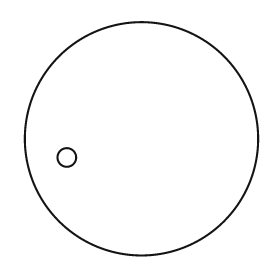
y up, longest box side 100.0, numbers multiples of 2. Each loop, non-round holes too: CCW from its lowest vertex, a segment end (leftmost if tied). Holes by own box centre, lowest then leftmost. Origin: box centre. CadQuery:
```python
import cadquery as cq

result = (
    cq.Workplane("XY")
    .moveTo(0.0, 0.0)
    .circle(50.0)
    .moveTo(-32.0, -8.0)
    .circle(4.0)
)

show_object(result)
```